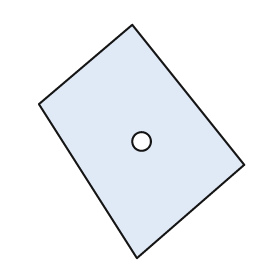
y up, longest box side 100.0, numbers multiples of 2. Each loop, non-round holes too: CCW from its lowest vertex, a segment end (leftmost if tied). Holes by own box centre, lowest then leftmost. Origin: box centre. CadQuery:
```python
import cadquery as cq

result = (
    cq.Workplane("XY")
    .moveTo(-2.0, -50.0)
    .lineTo(44.0, -10.0)
    .lineTo(-4.0, 50.0)
    .lineTo(-44.0, 16.0)
    .close()
    .moveTo(0.0, 0.0)
    .circle(4.0)
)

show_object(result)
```